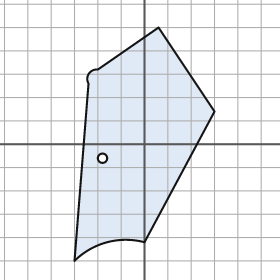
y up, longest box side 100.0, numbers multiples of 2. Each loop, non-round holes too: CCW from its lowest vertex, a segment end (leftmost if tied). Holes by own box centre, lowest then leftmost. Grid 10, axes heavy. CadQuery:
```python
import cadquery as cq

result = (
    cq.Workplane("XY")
    .moveTo(-30.0, -50.0)
    .threePointArc((-16.0, -42.0), (0.0, -42.0))
    .lineTo(30.0, 14.0)
    .lineTo(6.0, 50.0)
    .lineTo(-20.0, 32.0)
    .threePointArc((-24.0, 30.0), (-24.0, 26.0))
    .close()
    .moveTo(-18.0, -6.0)
    .circle(2.0)
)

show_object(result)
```